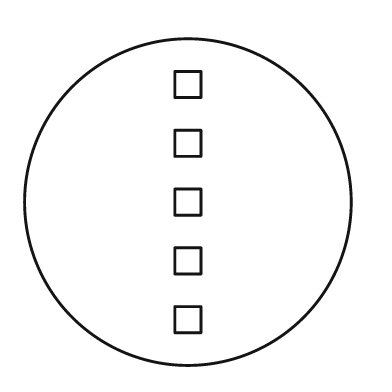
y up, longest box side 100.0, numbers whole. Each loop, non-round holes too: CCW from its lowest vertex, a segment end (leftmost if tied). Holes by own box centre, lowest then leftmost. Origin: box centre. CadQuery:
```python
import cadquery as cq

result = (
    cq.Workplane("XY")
    .moveTo(0.0, 0.0)
    .circle(50.0)
    .moveTo(-4.0, -40.0)
    .lineTo(4.0, -40.0)
    .lineTo(4.0, -32.0)
    .lineTo(-4.0, -32.0)
    .close()
    .moveTo(-4.0, -22.0)
    .lineTo(4.0, -22.0)
    .lineTo(4.0, -14.0)
    .lineTo(-4.0, -14.0)
    .close()
    .moveTo(-4.0, -4.0)
    .lineTo(4.0, -4.0)
    .lineTo(4.0, 4.0)
    .lineTo(-4.0, 4.0)
    .close()
    .moveTo(-4.0, 14.0)
    .lineTo(4.0, 14.0)
    .lineTo(4.0, 22.0)
    .lineTo(-4.0, 22.0)
    .close()
    .moveTo(-4.0, 32.0)
    .lineTo(4.0, 32.0)
    .lineTo(4.0, 40.0)
    .lineTo(-4.0, 40.0)
    .close()
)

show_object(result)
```